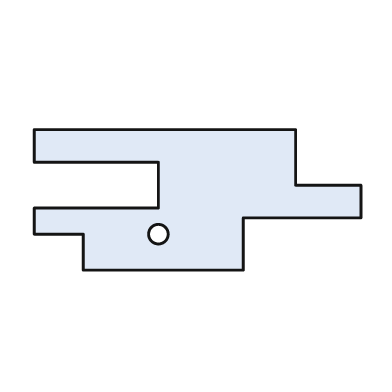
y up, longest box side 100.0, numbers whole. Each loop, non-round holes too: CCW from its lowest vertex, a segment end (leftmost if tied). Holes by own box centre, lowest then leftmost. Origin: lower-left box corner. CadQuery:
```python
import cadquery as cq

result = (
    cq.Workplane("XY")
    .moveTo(15.0, 0.0)
    .lineTo(64.0, 0.0)
    .lineTo(64.0, 16.0)
    .lineTo(100.0, 16.0)
    .lineTo(100.0, 26.0)
    .lineTo(80.0, 26.0)
    .lineTo(80.0, 43.0)
    .lineTo(0.0, 43.0)
    .lineTo(0.0, 33.0)
    .lineTo(38.0, 33.0)
    .lineTo(38.0, 19.0)
    .lineTo(0.0, 19.0)
    .lineTo(0.0, 11.0)
    .lineTo(15.0, 11.0)
    .close()
    .moveTo(38.0, 11.0)
    .circle(3.0)
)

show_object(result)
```